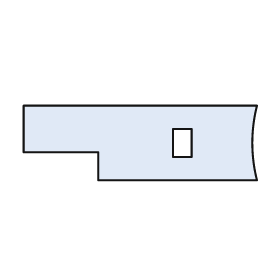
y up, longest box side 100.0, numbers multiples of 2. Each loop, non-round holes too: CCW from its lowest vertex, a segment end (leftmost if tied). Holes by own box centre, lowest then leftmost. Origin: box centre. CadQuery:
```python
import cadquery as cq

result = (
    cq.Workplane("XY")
    .moveTo(-18.0, -16.0)
    .lineTo(50.0, -16.0)
    .threePointArc((48.0, 0.0), (50.0, 16.0))
    .lineTo(-50.0, 16.0)
    .lineTo(-50.0, -4.0)
    .lineTo(-18.0, -4.0)
    .close()
    .moveTo(14.0, -6.0)
    .lineTo(22.0, -6.0)
    .lineTo(22.0, 6.0)
    .lineTo(14.0, 6.0)
    .close()
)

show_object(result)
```